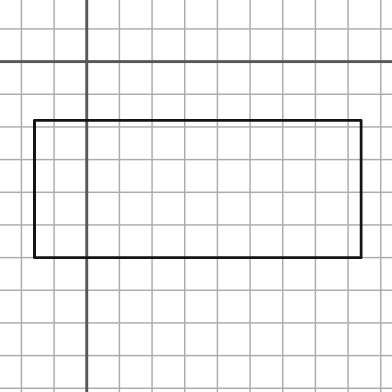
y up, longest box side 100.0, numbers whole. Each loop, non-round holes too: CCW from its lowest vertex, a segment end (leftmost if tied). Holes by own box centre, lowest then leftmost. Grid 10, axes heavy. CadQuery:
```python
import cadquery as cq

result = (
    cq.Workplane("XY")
    .moveTo(-16.0, -60.0)
    .lineTo(84.0, -60.0)
    .lineTo(84.0, -18.0)
    .lineTo(-16.0, -18.0)
    .close()
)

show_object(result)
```